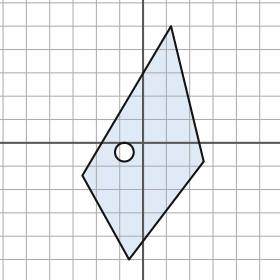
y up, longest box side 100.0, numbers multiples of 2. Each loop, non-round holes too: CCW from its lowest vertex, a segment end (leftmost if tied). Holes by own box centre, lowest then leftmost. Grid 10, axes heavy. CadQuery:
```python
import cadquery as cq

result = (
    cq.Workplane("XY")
    .moveTo(-6.0, -50.0)
    .lineTo(26.0, -8.0)
    .lineTo(12.0, 50.0)
    .lineTo(-26.0, -14.0)
    .close()
    .moveTo(-8.0, -4.0)
    .circle(4.0)
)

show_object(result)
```